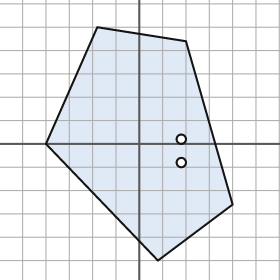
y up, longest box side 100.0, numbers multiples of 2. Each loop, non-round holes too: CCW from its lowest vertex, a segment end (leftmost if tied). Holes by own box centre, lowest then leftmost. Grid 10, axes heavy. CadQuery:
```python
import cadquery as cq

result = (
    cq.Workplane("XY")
    .moveTo(8.0, -50.0)
    .lineTo(40.0, -26.0)
    .lineTo(20.0, 44.0)
    .lineTo(-18.0, 50.0)
    .lineTo(-40.0, 0.0)
    .close()
    .moveTo(18.0, -8.0)
    .circle(2.0)
    .moveTo(18.0, 2.0)
    .circle(2.0)
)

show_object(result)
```